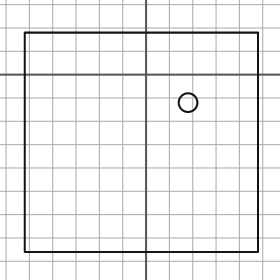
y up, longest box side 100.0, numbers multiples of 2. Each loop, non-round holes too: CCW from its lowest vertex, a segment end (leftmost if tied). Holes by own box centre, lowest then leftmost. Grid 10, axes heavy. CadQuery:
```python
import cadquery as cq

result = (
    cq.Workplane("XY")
    .moveTo(-52.0, -76.0)
    .lineTo(48.0, -76.0)
    .lineTo(48.0, 18.0)
    .lineTo(-52.0, 18.0)
    .close()
    .moveTo(18.0, -12.0)
    .circle(4.0)
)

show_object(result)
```